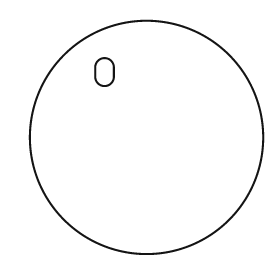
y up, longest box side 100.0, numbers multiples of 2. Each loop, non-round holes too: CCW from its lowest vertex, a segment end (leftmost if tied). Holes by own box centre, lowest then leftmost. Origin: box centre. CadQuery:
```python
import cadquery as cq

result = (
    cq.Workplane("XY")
    .moveTo(0.0, 0.0)
    .circle(50.0)
    .moveTo(-22.0, 26.0)
    .threePointArc((-18.0, 22.0), (-14.0, 26.0))
    .lineTo(-14.0, 30.0)
    .threePointArc((-18.0, 34.0), (-22.0, 30.0))
    .close()
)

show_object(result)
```